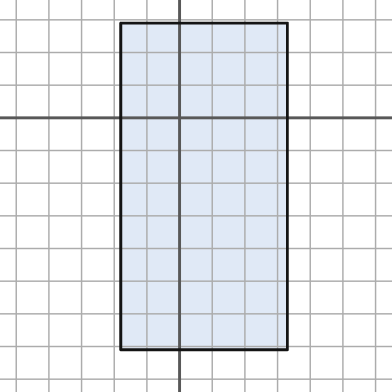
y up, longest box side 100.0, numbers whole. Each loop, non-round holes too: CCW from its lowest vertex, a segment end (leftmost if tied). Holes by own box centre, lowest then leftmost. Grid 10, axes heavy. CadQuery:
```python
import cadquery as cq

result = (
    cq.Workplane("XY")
    .moveTo(-18.0, -71.0)
    .lineTo(33.0, -71.0)
    .lineTo(33.0, 29.0)
    .lineTo(-18.0, 29.0)
    .close()
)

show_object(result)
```